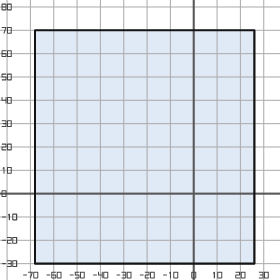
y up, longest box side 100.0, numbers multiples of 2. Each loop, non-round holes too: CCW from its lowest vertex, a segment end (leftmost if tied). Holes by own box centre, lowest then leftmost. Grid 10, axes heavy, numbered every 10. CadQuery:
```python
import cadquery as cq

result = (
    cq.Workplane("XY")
    .moveTo(-68.0, -30.0)
    .lineTo(26.0, -30.0)
    .lineTo(26.0, 70.0)
    .lineTo(-68.0, 70.0)
    .close()
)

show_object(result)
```